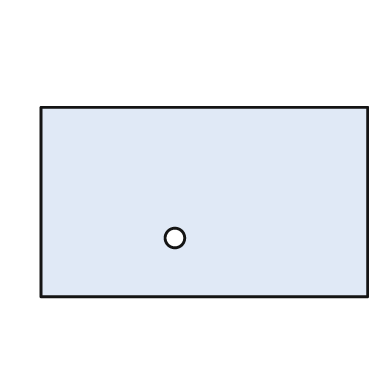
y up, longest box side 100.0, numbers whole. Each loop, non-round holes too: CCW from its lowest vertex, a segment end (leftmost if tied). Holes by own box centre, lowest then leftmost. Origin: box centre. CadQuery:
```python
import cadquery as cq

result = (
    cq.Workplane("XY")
    .moveTo(-50.0, -29.0)
    .lineTo(50.0, -29.0)
    .lineTo(50.0, 29.0)
    .lineTo(-50.0, 29.0)
    .close()
    .moveTo(-9.0, -11.0)
    .circle(3.0)
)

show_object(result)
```